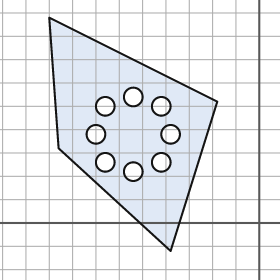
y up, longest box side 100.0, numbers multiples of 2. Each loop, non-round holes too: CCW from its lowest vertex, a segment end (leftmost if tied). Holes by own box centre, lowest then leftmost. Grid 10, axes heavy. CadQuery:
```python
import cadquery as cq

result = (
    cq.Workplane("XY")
    .moveTo(-38.0, -12.0)
    .lineTo(-18.0, 52.0)
    .lineTo(-90.0, 88.0)
    .lineTo(-86.0, 32.0)
    .close()
    .moveTo(-54.0, 22.0)
    .circle(4.0)
    .moveTo(-66.0, 26.0)
    .circle(4.0)
    .moveTo(-42.0, 26.0)
    .circle(4.0)
    .moveTo(-70.0, 38.0)
    .circle(4.0)
    .moveTo(-38.0, 38.0)
    .circle(4.0)
    .moveTo(-66.0, 50.0)
    .circle(4.0)
    .moveTo(-42.0, 50.0)
    .circle(4.0)
    .moveTo(-54.0, 54.0)
    .circle(4.0)
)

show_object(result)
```